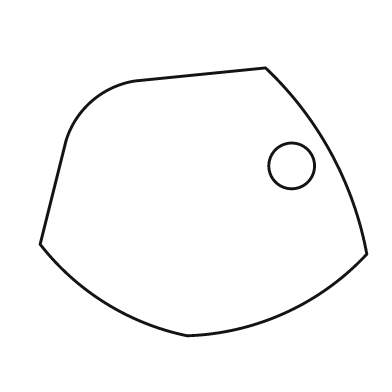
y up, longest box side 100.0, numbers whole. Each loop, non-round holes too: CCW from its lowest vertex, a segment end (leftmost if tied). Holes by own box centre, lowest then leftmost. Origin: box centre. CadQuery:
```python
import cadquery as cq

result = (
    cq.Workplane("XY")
    .moveTo(-5.0, -41.0)
    .threePointArc((25.0, -34.0), (50.0, -16.0))
    .threePointArc((39.0, 15.0), (19.0, 41.0))
    .lineTo(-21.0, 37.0)
    .threePointArc((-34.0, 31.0), (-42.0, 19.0))
    .lineTo(-50.0, -13.0)
    .threePointArc((-30.0, -31.0), (-5.0, -41.0))
    .close()
    .moveTo(27.0, 11.0)
    .circle(7.0)
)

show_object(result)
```